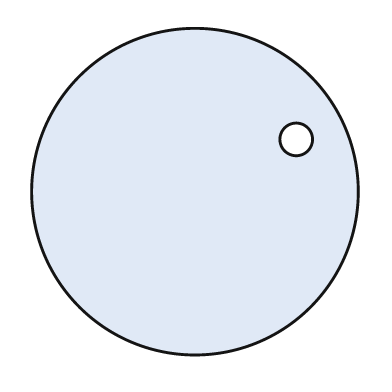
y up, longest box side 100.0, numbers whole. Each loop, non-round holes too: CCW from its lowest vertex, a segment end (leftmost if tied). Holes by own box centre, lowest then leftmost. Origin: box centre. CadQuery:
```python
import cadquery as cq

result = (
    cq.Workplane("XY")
    .moveTo(0.0, 0.0)
    .circle(50.0)
    .moveTo(31.0, 16.0)
    .circle(5.0)
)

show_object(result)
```